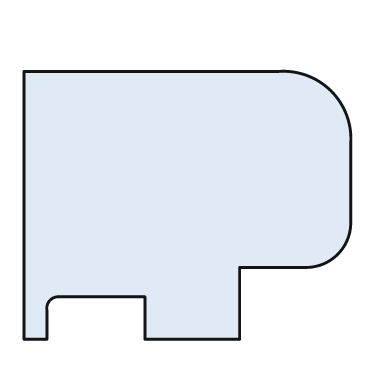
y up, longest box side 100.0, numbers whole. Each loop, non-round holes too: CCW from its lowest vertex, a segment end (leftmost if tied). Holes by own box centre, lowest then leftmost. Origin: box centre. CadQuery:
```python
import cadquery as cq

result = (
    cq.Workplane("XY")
    .moveTo(-50.0, -41.0)
    .lineTo(-43.0, -41.0)
    .lineTo(-43.0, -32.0)
    .threePointArc((-42.0, -29.0), (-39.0, -28.0))
    .lineTo(-13.0, -28.0)
    .lineTo(-13.0, -41.0)
    .lineTo(16.0, -41.0)
    .lineTo(16.0, -19.0)
    .lineTo(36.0, -19.0)
    .threePointArc((46.0, -15.0), (50.0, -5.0))
    .lineTo(50.0, 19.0)
    .threePointArc((44.0, 35.0), (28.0, 41.0))
    .lineTo(-50.0, 41.0)
    .close()
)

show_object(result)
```